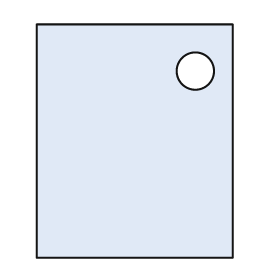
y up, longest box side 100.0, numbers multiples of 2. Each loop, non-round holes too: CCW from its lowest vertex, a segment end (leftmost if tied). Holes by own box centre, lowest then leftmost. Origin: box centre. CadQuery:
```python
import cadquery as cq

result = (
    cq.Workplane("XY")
    .moveTo(-42.0, -50.0)
    .lineTo(42.0, -50.0)
    .lineTo(42.0, 50.0)
    .lineTo(-42.0, 50.0)
    .close()
    .moveTo(26.0, 30.0)
    .circle(8.0)
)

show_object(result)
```